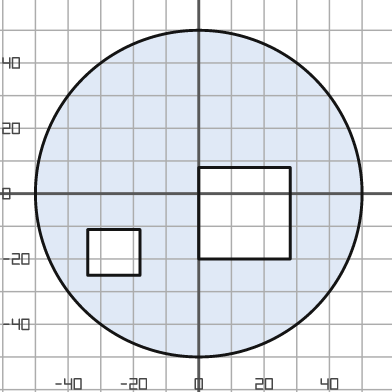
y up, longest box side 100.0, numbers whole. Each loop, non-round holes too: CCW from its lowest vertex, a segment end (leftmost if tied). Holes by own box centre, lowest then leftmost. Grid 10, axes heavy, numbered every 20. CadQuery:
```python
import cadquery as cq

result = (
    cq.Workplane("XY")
    .moveTo(0.0, 0.0)
    .circle(50.0)
    .moveTo(-34.0, -25.0)
    .lineTo(-18.0, -25.0)
    .lineTo(-18.0, -11.0)
    .lineTo(-34.0, -11.0)
    .close()
    .moveTo(0.0, -20.0)
    .lineTo(28.0, -20.0)
    .lineTo(28.0, 8.0)
    .lineTo(0.0, 8.0)
    .close()
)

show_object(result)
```